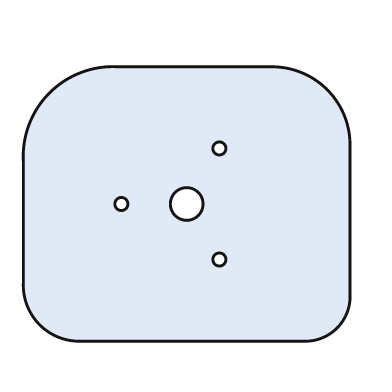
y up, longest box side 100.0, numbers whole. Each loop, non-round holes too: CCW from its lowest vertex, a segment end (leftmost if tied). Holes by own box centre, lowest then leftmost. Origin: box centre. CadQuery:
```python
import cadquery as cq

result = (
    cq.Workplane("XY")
    .moveTo(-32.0, -42.0)
    .lineTo(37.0, -42.0)
    .threePointArc((46.0, -38.0), (50.0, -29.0))
    .lineTo(50.0, 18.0)
    .threePointArc((43.0, 35.0), (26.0, 42.0))
    .lineTo(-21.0, 42.0)
    .threePointArc((-42.0, 34.0), (-50.0, 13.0))
    .lineTo(-50.0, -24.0)
    .threePointArc((-45.0, -37.0), (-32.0, -42.0))
    .close()
    .moveTo(10.0, -17.0)
    .circle(2.0)
    .moveTo(-20.0, 0.0)
    .circle(2.0)
    .moveTo(0.0, 0.0)
    .circle(5.0)
    .moveTo(10.0, 17.0)
    .circle(2.0)
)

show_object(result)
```